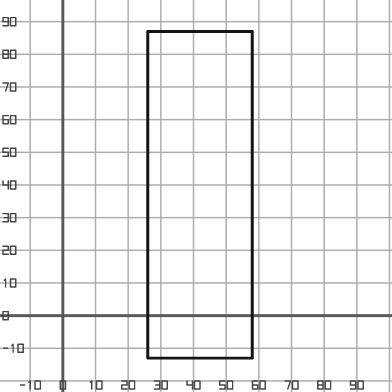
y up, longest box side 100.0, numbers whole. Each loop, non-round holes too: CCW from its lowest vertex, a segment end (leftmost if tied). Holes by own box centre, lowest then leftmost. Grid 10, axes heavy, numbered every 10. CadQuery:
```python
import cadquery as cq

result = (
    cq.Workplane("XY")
    .moveTo(26.0, -13.0)
    .lineTo(58.0, -13.0)
    .lineTo(58.0, 87.0)
    .lineTo(26.0, 87.0)
    .close()
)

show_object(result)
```